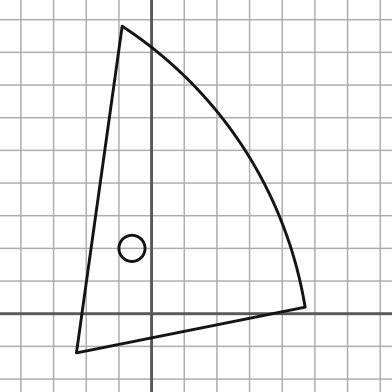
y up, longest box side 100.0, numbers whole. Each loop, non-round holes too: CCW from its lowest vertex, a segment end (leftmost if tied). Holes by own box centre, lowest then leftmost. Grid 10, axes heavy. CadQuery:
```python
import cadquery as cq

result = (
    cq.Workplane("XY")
    .moveTo(-23.0, -12.0)
    .lineTo(47.0, 2.0)
    .threePointArc((28.0, 51.0), (-9.0, 88.0))
    .close()
    .moveTo(-6.0, 20.0)
    .circle(4.0)
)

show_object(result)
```